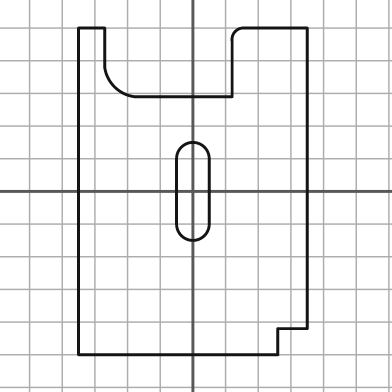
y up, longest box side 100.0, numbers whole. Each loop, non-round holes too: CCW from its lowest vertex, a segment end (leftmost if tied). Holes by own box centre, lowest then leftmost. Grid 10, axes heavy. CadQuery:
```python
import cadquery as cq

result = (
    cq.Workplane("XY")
    .moveTo(-35.0, -50.0)
    .lineTo(26.0, -50.0)
    .lineTo(26.0, -42.0)
    .lineTo(35.0, -42.0)
    .lineTo(35.0, 50.0)
    .lineTo(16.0, 50.0)
    .threePointArc((13.0, 49.0), (12.0, 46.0))
    .lineTo(12.0, 29.0)
    .lineTo(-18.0, 29.0)
    .threePointArc((-24.0, 32.0), (-27.0, 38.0))
    .lineTo(-27.0, 50.0)
    .lineTo(-35.0, 50.0)
    .close()
    .moveTo(-5.0, -10.0)
    .threePointArc((0.0, -15.0), (5.0, -10.0))
    .lineTo(5.0, 10.0)
    .threePointArc((0.0, 15.0), (-5.0, 10.0))
    .close()
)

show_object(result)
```